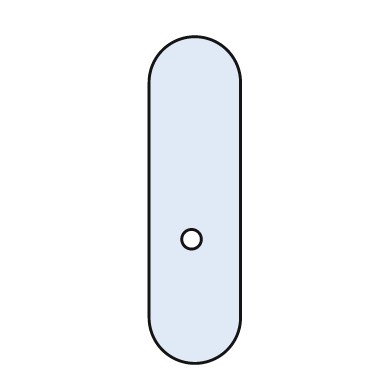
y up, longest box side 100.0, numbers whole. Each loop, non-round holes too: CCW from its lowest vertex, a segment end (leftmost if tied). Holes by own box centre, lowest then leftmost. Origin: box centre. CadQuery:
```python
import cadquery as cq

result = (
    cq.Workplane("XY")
    .moveTo(-14.0, -36.0)
    .threePointArc((0.0, -50.0), (14.0, -36.0))
    .lineTo(14.0, 36.0)
    .threePointArc((0.0, 50.0), (-14.0, 36.0))
    .close()
    .moveTo(-1.0, -12.0)
    .circle(3.0)
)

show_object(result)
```